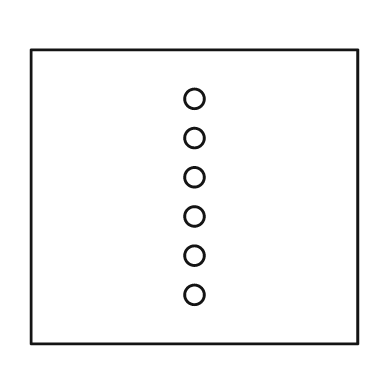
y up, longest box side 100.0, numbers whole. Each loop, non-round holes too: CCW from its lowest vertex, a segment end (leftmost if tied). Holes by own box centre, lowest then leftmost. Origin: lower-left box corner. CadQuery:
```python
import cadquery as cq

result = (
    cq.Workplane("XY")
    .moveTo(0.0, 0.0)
    .lineTo(100.0, 0.0)
    .lineTo(100.0, 90.0)
    .lineTo(0.0, 90.0)
    .close()
    .moveTo(50.0, 15.0)
    .circle(3.0)
    .moveTo(50.0, 27.0)
    .circle(3.0)
    .moveTo(50.0, 39.0)
    .circle(3.0)
    .moveTo(50.0, 51.0)
    .circle(3.0)
    .moveTo(50.0, 63.0)
    .circle(3.0)
    .moveTo(50.0, 75.0)
    .circle(3.0)
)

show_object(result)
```